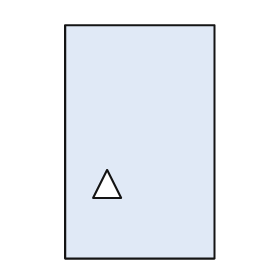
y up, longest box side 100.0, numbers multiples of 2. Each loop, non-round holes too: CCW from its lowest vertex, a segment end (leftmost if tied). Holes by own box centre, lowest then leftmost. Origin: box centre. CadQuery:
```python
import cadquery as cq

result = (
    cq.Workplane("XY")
    .moveTo(-32.0, -50.0)
    .lineTo(32.0, -50.0)
    .lineTo(32.0, 50.0)
    .lineTo(-32.0, 50.0)
    .close()
    .moveTo(-20.0, -24.0)
    .lineTo(-8.0, -24.0)
    .lineTo(-14.0, -12.0)
    .close()
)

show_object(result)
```